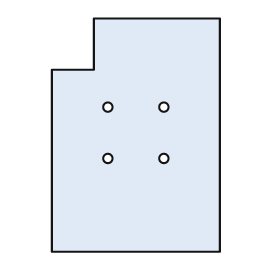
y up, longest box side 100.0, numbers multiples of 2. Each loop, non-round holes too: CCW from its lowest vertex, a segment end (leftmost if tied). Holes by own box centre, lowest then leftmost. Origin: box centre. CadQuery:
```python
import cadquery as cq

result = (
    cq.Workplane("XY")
    .moveTo(-36.0, -50.0)
    .lineTo(36.0, -50.0)
    .lineTo(36.0, 50.0)
    .lineTo(-18.0, 50.0)
    .lineTo(-18.0, 28.0)
    .lineTo(-36.0, 28.0)
    .close()
    .moveTo(-12.0, -10.0)
    .circle(2.0)
    .moveTo(12.0, -10.0)
    .circle(2.0)
    .moveTo(-12.0, 12.0)
    .circle(2.0)
    .moveTo(12.0, 12.0)
    .circle(2.0)
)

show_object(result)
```